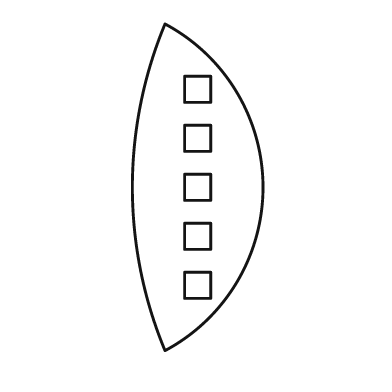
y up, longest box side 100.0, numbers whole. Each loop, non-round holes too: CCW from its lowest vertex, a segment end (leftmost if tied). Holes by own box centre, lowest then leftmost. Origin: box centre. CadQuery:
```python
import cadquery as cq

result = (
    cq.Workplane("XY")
    .moveTo(-10.0, -50.0)
    .threePointArc((20.0, 0.0), (-10.0, 50.0))
    .threePointArc((-20.0, 0.0), (-10.0, -50.0))
    .close()
    .moveTo(-4.0, -34.0)
    .lineTo(4.0, -34.0)
    .lineTo(4.0, -26.0)
    .lineTo(-4.0, -26.0)
    .close()
    .moveTo(-4.0, -19.0)
    .lineTo(4.0, -19.0)
    .lineTo(4.0, -11.0)
    .lineTo(-4.0, -11.0)
    .close()
    .moveTo(-4.0, -4.0)
    .lineTo(4.0, -4.0)
    .lineTo(4.0, 4.0)
    .lineTo(-4.0, 4.0)
    .close()
    .moveTo(-4.0, 11.0)
    .lineTo(4.0, 11.0)
    .lineTo(4.0, 19.0)
    .lineTo(-4.0, 19.0)
    .close()
    .moveTo(-4.0, 26.0)
    .lineTo(4.0, 26.0)
    .lineTo(4.0, 34.0)
    .lineTo(-4.0, 34.0)
    .close()
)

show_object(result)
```